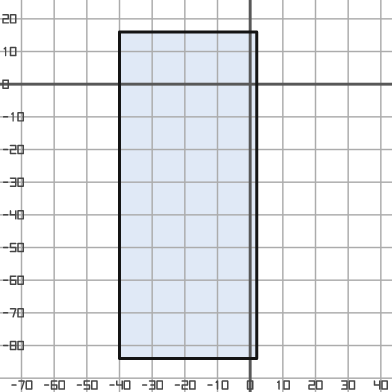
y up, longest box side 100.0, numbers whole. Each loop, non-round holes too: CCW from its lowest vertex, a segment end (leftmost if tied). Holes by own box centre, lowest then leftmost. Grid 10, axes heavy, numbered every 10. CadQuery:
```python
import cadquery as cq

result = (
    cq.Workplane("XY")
    .moveTo(-40.0, -84.0)
    .lineTo(2.0, -84.0)
    .lineTo(2.0, 16.0)
    .lineTo(-40.0, 16.0)
    .close()
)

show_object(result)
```